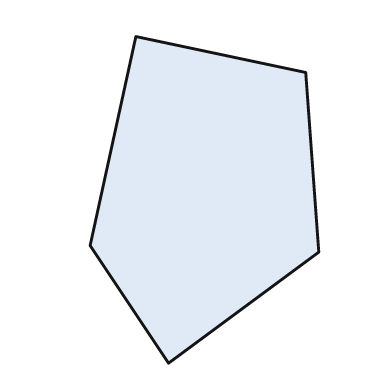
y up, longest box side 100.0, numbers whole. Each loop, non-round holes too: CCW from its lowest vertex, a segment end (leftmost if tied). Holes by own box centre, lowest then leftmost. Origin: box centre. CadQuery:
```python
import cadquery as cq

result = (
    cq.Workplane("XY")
    .moveTo(-11.0, -50.0)
    .lineTo(35.0, -16.0)
    .lineTo(31.0, 39.0)
    .lineTo(-21.0, 50.0)
    .lineTo(-35.0, -14.0)
    .close()
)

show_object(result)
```